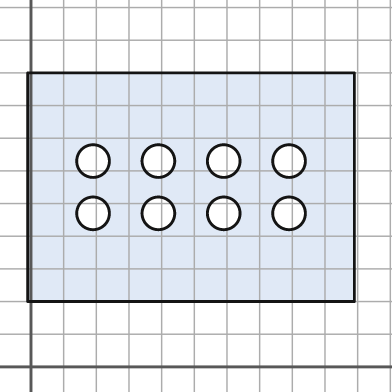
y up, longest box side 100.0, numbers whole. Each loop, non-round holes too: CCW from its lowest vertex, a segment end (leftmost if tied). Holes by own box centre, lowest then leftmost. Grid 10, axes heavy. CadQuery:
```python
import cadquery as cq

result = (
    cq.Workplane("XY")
    .moveTo(-1.0, 20.0)
    .lineTo(99.0, 20.0)
    .lineTo(99.0, 90.0)
    .lineTo(-1.0, 90.0)
    .close()
    .moveTo(19.0, 47.0)
    .circle(5.0)
    .moveTo(39.0, 47.0)
    .circle(5.0)
    .moveTo(59.0, 47.0)
    .circle(5.0)
    .moveTo(79.0, 47.0)
    .circle(5.0)
    .moveTo(19.0, 63.0)
    .circle(5.0)
    .moveTo(39.0, 63.0)
    .circle(5.0)
    .moveTo(59.0, 63.0)
    .circle(5.0)
    .moveTo(79.0, 63.0)
    .circle(5.0)
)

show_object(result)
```